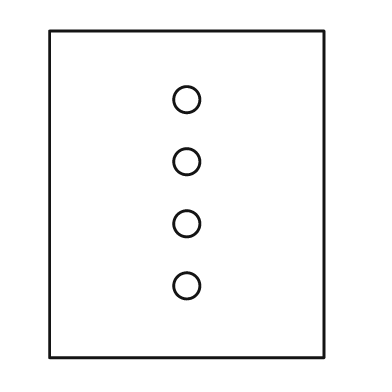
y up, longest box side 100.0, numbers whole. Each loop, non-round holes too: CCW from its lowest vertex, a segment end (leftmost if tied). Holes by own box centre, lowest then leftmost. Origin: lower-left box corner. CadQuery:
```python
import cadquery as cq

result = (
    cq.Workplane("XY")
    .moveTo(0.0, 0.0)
    .lineTo(84.0, 0.0)
    .lineTo(84.0, 100.0)
    .lineTo(0.0, 100.0)
    .close()
    .moveTo(42.0, 22.0)
    .circle(4.0)
    .moveTo(42.0, 41.0)
    .circle(4.0)
    .moveTo(42.0, 60.0)
    .circle(4.0)
    .moveTo(42.0, 79.0)
    .circle(4.0)
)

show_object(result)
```